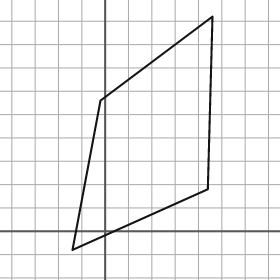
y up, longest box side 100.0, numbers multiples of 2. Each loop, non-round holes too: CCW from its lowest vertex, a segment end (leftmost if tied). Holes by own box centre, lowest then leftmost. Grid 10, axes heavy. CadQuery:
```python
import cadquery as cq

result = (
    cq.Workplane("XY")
    .moveTo(-14.0, -8.0)
    .lineTo(44.0, 18.0)
    .lineTo(46.0, 92.0)
    .lineTo(-2.0, 56.0)
    .close()
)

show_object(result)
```